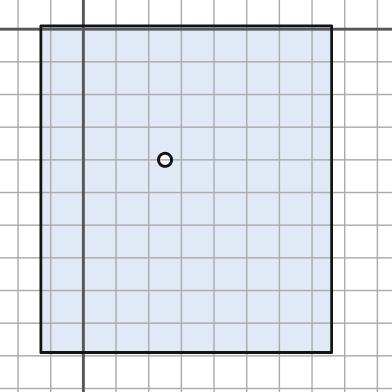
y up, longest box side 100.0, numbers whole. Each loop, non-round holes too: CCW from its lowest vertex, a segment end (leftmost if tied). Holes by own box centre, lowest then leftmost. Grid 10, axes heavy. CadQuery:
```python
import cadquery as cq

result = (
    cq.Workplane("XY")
    .moveTo(-13.0, -99.0)
    .lineTo(76.0, -99.0)
    .lineTo(76.0, 1.0)
    .lineTo(-13.0, 1.0)
    .close()
    .moveTo(25.0, -40.0)
    .circle(2.0)
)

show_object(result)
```